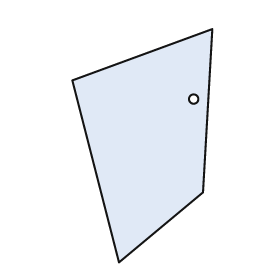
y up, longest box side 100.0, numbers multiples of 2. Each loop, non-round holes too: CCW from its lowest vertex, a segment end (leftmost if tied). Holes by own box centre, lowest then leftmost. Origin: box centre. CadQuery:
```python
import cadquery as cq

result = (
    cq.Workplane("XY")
    .moveTo(-10.0, -50.0)
    .lineTo(26.0, -20.0)
    .lineTo(30.0, 50.0)
    .lineTo(-30.0, 28.0)
    .close()
    .moveTo(22.0, 20.0)
    .circle(2.0)
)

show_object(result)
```